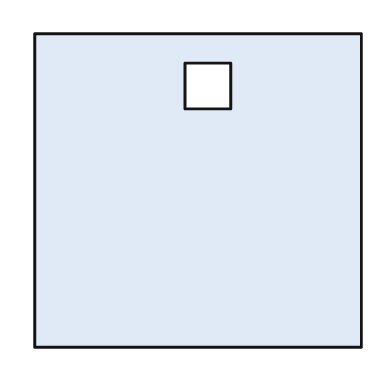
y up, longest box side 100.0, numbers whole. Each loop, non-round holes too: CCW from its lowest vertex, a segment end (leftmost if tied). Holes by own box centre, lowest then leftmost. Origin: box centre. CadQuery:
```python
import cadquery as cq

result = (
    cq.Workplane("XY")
    .moveTo(-50.0, -48.0)
    .lineTo(50.0, -48.0)
    .lineTo(50.0, 48.0)
    .lineTo(-50.0, 48.0)
    .close()
    .moveTo(-4.0, 25.0)
    .lineTo(10.0, 25.0)
    .lineTo(10.0, 39.0)
    .lineTo(-4.0, 39.0)
    .close()
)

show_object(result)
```